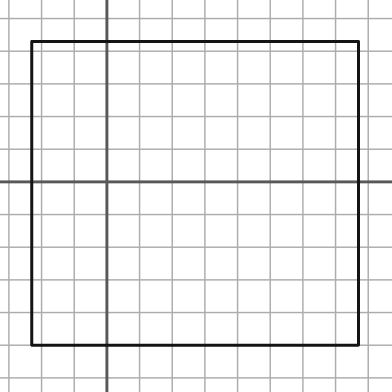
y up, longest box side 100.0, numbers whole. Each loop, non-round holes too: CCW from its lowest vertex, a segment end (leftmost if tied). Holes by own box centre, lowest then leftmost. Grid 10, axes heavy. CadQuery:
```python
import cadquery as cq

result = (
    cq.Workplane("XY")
    .moveTo(-23.0, -50.0)
    .lineTo(77.0, -50.0)
    .lineTo(77.0, 43.0)
    .lineTo(-23.0, 43.0)
    .close()
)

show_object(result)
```